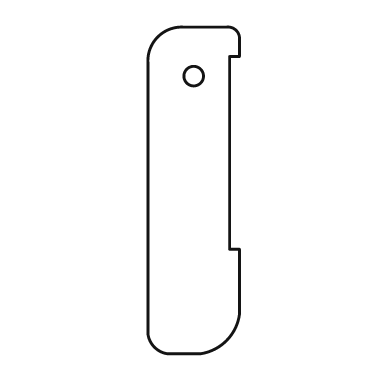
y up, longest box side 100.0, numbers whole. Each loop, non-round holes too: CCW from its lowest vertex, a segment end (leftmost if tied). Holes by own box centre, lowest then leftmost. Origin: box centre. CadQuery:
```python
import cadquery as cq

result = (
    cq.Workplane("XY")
    .moveTo(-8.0, -50.0)
    .lineTo(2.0, -50.0)
    .threePointArc((10.0, -46.0), (14.0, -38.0))
    .lineTo(14.0, -18.0)
    .lineTo(11.0, -18.0)
    .lineTo(11.0, 41.0)
    .lineTo(14.0, 41.0)
    .lineTo(14.0, 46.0)
    .threePointArc((13.0, 49.0), (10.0, 50.0))
    .lineTo(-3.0, 50.0)
    .threePointArc((-11.0, 47.0), (-14.0, 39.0))
    .lineTo(-14.0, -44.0)
    .threePointArc((-12.0, -48.0), (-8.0, -50.0))
    .close()
    .moveTo(0.0, 35.0)
    .circle(3.0)
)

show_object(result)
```